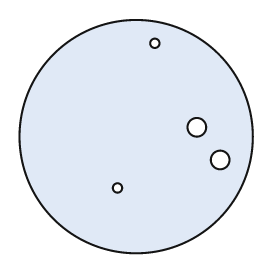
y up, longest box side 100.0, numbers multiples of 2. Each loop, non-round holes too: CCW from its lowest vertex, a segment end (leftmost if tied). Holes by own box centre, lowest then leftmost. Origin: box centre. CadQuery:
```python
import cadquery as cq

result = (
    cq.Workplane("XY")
    .moveTo(0.0, 0.0)
    .circle(50.0)
    .moveTo(-8.0, -22.0)
    .circle(2.0)
    .moveTo(36.0, -10.0)
    .circle(4.0)
    .moveTo(26.0, 4.0)
    .circle(4.0)
    .moveTo(8.0, 40.0)
    .circle(2.0)
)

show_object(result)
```